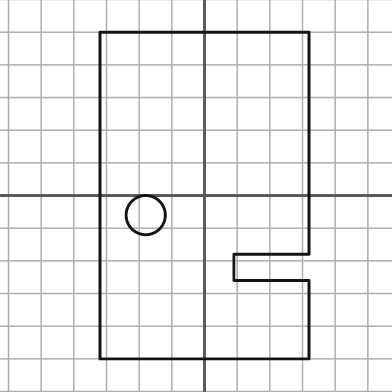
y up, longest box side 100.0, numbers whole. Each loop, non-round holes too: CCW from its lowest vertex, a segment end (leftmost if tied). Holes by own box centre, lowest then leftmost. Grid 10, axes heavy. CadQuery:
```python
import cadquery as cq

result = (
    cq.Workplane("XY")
    .moveTo(-32.0, -50.0)
    .lineTo(32.0, -50.0)
    .lineTo(32.0, -26.0)
    .lineTo(9.0, -26.0)
    .lineTo(9.0, -18.0)
    .lineTo(32.0, -18.0)
    .lineTo(32.0, 50.0)
    .lineTo(-32.0, 50.0)
    .close()
    .moveTo(-18.0, -6.0)
    .circle(6.0)
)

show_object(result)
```